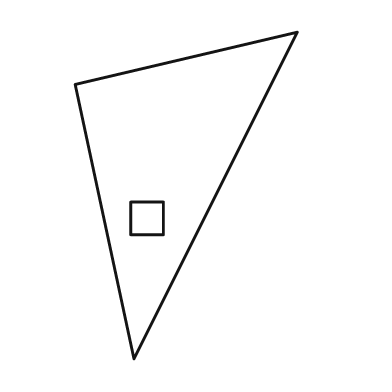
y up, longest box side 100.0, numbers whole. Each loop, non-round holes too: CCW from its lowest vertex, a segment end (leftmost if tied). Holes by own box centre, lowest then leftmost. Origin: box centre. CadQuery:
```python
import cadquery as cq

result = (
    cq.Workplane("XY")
    .moveTo(-16.0, -50.0)
    .lineTo(34.0, 50.0)
    .lineTo(-34.0, 34.0)
    .close()
    .moveTo(-17.0, -12.0)
    .lineTo(-7.0, -12.0)
    .lineTo(-7.0, -2.0)
    .lineTo(-17.0, -2.0)
    .close()
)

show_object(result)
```